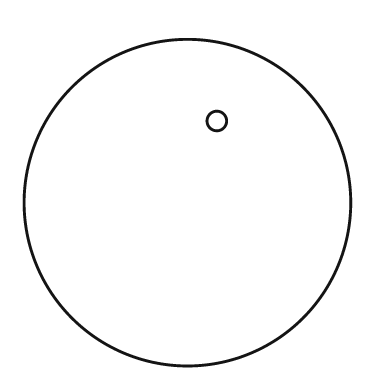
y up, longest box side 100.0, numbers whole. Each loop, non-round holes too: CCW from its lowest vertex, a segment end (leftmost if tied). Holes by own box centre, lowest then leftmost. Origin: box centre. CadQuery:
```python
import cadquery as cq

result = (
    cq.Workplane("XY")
    .moveTo(0.0, 0.0)
    .circle(50.0)
    .moveTo(9.0, 25.0)
    .circle(3.0)
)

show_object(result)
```